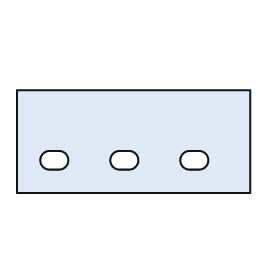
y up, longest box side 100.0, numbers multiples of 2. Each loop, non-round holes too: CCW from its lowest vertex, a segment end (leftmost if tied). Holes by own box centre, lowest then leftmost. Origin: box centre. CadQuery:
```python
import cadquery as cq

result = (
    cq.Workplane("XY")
    .moveTo(-50.0, -22.0)
    .lineTo(50.0, -22.0)
    .lineTo(50.0, 22.0)
    .lineTo(-50.0, 22.0)
    .close()
    .moveTo(-36.0, -12.0)
    .lineTo(-32.0, -12.0)
    .threePointArc((-28.0, -8.0), (-32.0, -4.0))
    .lineTo(-36.0, -4.0)
    .threePointArc((-40.0, -8.0), (-36.0, -12.0))
    .close()
    .moveTo(-6.0, -12.0)
    .lineTo(-2.0, -12.0)
    .threePointArc((2.0, -8.0), (-2.0, -4.0))
    .lineTo(-6.0, -4.0)
    .threePointArc((-10.0, -8.0), (-6.0, -12.0))
    .close()
    .moveTo(24.0, -12.0)
    .lineTo(28.0, -12.0)
    .threePointArc((32.0, -8.0), (28.0, -4.0))
    .lineTo(24.0, -4.0)
    .threePointArc((20.0, -8.0), (24.0, -12.0))
    .close()
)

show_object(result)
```